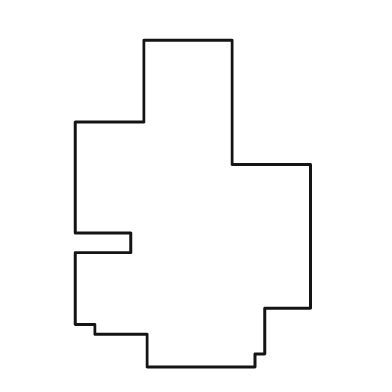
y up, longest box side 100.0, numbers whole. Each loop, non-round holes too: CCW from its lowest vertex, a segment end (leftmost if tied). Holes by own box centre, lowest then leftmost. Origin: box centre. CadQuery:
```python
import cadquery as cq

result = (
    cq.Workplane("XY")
    .moveTo(-14.0, -50.0)
    .lineTo(19.0, -50.0)
    .lineTo(19.0, -46.0)
    .lineTo(22.0, -46.0)
    .lineTo(22.0, -32.0)
    .lineTo(36.0, -32.0)
    .lineTo(36.0, 12.0)
    .lineTo(12.0, 12.0)
    .lineTo(12.0, 50.0)
    .lineTo(-15.0, 50.0)
    .lineTo(-15.0, 25.0)
    .lineTo(-36.0, 25.0)
    .lineTo(-36.0, -9.0)
    .lineTo(-19.0, -9.0)
    .lineTo(-19.0, -15.0)
    .lineTo(-36.0, -15.0)
    .lineTo(-36.0, -37.0)
    .lineTo(-30.0, -37.0)
    .lineTo(-30.0, -40.0)
    .lineTo(-14.0, -40.0)
    .close()
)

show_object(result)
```